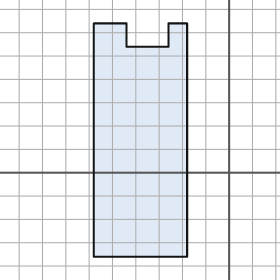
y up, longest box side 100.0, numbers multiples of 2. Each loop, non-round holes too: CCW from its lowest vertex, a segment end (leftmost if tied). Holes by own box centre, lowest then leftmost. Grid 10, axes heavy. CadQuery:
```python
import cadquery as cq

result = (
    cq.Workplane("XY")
    .moveTo(-58.0, -36.0)
    .lineTo(-18.0, -36.0)
    .lineTo(-18.0, 64.0)
    .lineTo(-26.0, 64.0)
    .lineTo(-26.0, 54.0)
    .lineTo(-44.0, 54.0)
    .lineTo(-44.0, 64.0)
    .lineTo(-58.0, 64.0)
    .close()
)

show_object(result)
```